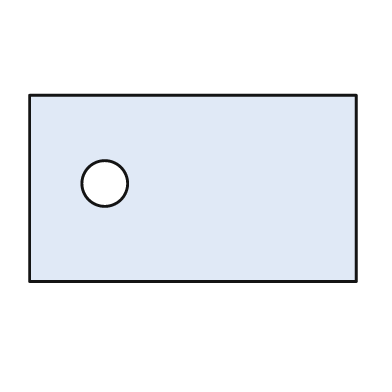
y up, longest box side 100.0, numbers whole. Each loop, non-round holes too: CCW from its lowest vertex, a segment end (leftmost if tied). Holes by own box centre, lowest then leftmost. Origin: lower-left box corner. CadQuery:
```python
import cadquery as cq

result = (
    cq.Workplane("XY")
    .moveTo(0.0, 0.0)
    .lineTo(100.0, 0.0)
    .lineTo(100.0, 57.0)
    .lineTo(0.0, 57.0)
    .close()
    .moveTo(23.0, 30.0)
    .circle(7.0)
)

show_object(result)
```